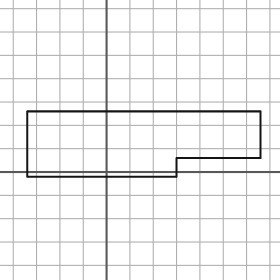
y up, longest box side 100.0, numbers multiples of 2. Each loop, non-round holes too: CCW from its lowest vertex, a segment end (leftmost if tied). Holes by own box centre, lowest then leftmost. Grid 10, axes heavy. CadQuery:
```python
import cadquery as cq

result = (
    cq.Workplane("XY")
    .moveTo(-34.0, -2.0)
    .lineTo(30.0, -2.0)
    .lineTo(30.0, 6.0)
    .lineTo(66.0, 6.0)
    .lineTo(66.0, 26.0)
    .lineTo(-34.0, 26.0)
    .close()
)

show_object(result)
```